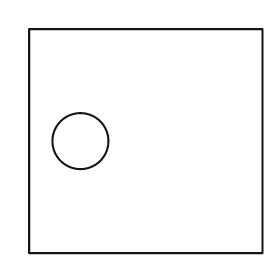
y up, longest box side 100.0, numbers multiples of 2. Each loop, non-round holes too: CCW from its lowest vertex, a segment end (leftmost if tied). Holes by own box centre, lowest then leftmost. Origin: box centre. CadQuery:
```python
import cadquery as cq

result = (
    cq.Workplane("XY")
    .moveTo(-50.0, -48.0)
    .lineTo(50.0, -48.0)
    .lineTo(50.0, 48.0)
    .lineTo(-50.0, 48.0)
    .close()
    .moveTo(-28.0, 0.0)
    .circle(12.0)
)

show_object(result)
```